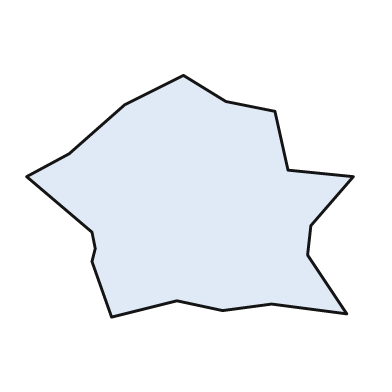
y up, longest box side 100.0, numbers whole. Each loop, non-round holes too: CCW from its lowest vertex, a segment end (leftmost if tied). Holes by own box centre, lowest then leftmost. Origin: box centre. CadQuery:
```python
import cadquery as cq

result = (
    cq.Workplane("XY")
    .moveTo(-24.0, -37.0)
    .lineTo(-4.0, -32.0)
    .lineTo(10.0, -35.0)
    .lineTo(25.0, -33.0)
    .lineTo(48.0, -36.0)
    .lineTo(36.0, -18.0)
    .lineTo(37.0, -9.0)
    .lineTo(50.0, 6.0)
    .lineTo(30.0, 8.0)
    .lineTo(26.0, 26.0)
    .lineTo(11.0, 29.0)
    .lineTo(-2.0, 37.0)
    .lineTo(-20.0, 28.0)
    .lineTo(-37.0, 13.0)
    .lineTo(-50.0, 6.0)
    .lineTo(-30.0, -11.0)
    .lineTo(-29.0, -16.0)
    .lineTo(-30.0, -20.0)
    .close()
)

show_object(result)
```